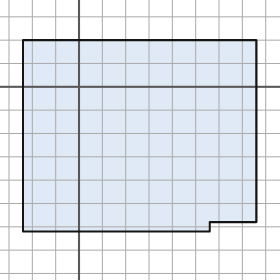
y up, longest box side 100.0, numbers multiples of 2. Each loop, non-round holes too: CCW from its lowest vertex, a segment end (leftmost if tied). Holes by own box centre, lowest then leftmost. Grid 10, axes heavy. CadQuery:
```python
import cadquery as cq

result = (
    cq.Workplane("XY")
    .moveTo(-24.0, -62.0)
    .lineTo(56.0, -62.0)
    .lineTo(56.0, -58.0)
    .lineTo(76.0, -58.0)
    .lineTo(76.0, 20.0)
    .lineTo(-24.0, 20.0)
    .close()
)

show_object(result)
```